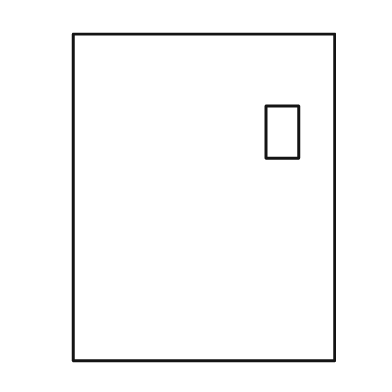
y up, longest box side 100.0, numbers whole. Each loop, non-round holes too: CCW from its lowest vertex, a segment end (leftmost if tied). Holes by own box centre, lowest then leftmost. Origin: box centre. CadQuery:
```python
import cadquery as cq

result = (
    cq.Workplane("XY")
    .moveTo(-40.0, -50.0)
    .lineTo(40.0, -50.0)
    .lineTo(40.0, 50.0)
    .lineTo(-40.0, 50.0)
    .close()
    .moveTo(19.0, 12.0)
    .lineTo(29.0, 12.0)
    .lineTo(29.0, 28.0)
    .lineTo(19.0, 28.0)
    .close()
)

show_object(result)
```